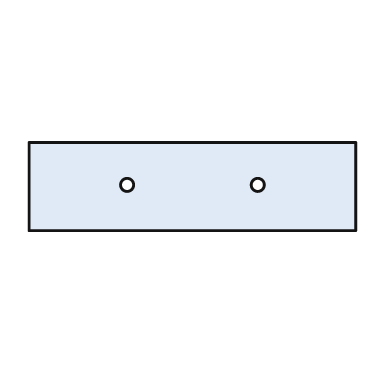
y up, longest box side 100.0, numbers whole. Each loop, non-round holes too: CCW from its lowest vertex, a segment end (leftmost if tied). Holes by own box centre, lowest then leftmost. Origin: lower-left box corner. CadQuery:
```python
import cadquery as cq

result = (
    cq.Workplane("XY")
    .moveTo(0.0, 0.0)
    .lineTo(100.0, 0.0)
    .lineTo(100.0, 27.0)
    .lineTo(0.0, 27.0)
    .close()
    .moveTo(30.0, 14.0)
    .circle(2.0)
    .moveTo(70.0, 14.0)
    .circle(2.0)
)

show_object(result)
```